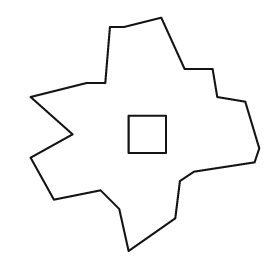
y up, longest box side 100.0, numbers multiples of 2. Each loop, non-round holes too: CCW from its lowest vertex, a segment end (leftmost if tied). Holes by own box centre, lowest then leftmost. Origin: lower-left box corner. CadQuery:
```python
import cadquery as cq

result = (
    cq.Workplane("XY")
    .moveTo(42.0, 0.0)
    .lineTo(62.0, 14.0)
    .lineTo(64.0, 30.0)
    .lineTo(70.0, 34.0)
    .lineTo(96.0, 38.0)
    .lineTo(98.0, 44.0)
    .lineTo(92.0, 64.0)
    .lineTo(80.0, 66.0)
    .lineTo(78.0, 78.0)
    .lineTo(66.0, 78.0)
    .lineTo(56.0, 100.0)
    .lineTo(40.0, 96.0)
    .lineTo(34.0, 96.0)
    .lineTo(32.0, 72.0)
    .lineTo(24.0, 72.0)
    .lineTo(0.0, 66.0)
    .lineTo(18.0, 50.0)
    .lineTo(0.0, 40.0)
    .lineTo(10.0, 22.0)
    .lineTo(30.0, 26.0)
    .lineTo(38.0, 18.0)
    .close()
    .moveTo(42.0, 42.0)
    .lineTo(58.0, 42.0)
    .lineTo(58.0, 58.0)
    .lineTo(42.0, 58.0)
    .close()
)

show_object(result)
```